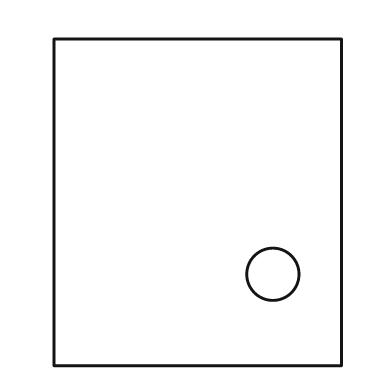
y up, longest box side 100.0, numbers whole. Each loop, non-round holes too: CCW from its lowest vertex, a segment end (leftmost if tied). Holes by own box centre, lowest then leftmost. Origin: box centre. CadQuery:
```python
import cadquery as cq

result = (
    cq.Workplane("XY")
    .moveTo(-44.0, -50.0)
    .lineTo(44.0, -50.0)
    .lineTo(44.0, 50.0)
    .lineTo(-44.0, 50.0)
    .close()
    .moveTo(23.0, -22.0)
    .circle(8.0)
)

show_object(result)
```